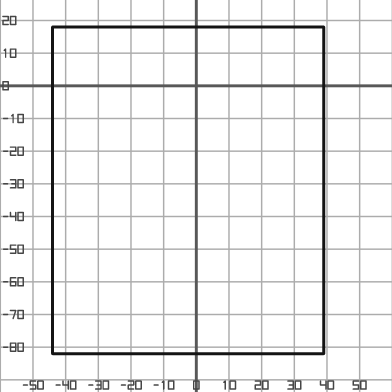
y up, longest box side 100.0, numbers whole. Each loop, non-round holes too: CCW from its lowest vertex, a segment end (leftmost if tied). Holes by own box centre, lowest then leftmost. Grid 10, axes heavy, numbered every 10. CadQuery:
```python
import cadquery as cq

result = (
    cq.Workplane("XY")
    .moveTo(-44.0, -82.0)
    .lineTo(39.0, -82.0)
    .lineTo(39.0, 18.0)
    .lineTo(-44.0, 18.0)
    .close()
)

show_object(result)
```